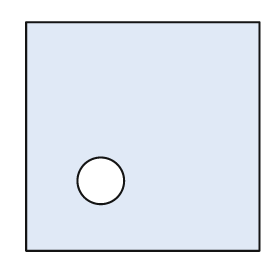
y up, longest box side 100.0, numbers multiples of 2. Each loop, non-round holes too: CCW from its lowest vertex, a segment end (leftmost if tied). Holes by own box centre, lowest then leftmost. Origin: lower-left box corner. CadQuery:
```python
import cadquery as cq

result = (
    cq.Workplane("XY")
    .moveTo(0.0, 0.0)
    .lineTo(100.0, 0.0)
    .lineTo(100.0, 98.0)
    .lineTo(0.0, 98.0)
    .close()
    .moveTo(32.0, 30.0)
    .circle(10.0)
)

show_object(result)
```